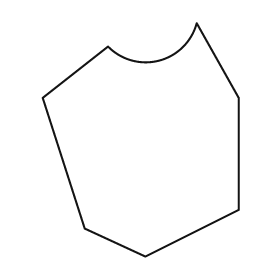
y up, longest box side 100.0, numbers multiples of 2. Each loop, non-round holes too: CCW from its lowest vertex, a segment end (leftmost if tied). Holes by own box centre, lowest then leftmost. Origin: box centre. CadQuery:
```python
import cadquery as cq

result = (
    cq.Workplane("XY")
    .moveTo(2.0, -50.0)
    .lineTo(42.0, -30.0)
    .lineTo(42.0, 18.0)
    .lineTo(24.0, 50.0)
    .threePointArc((8.0, 34.0), (-14.0, 40.0))
    .lineTo(-42.0, 18.0)
    .lineTo(-24.0, -38.0)
    .close()
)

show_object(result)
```